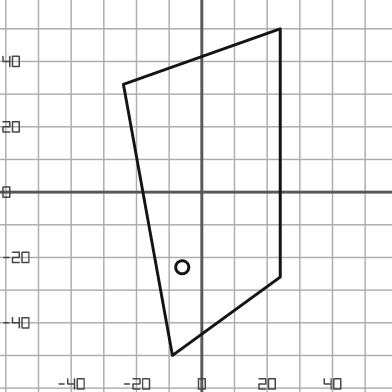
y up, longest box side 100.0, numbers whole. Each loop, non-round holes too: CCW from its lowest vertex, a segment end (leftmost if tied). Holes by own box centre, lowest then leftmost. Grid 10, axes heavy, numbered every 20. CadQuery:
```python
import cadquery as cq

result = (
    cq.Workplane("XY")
    .moveTo(-9.0, -50.0)
    .lineTo(24.0, -26.0)
    .lineTo(24.0, 50.0)
    .lineTo(-24.0, 33.0)
    .close()
    .moveTo(-6.0, -23.0)
    .circle(2.0)
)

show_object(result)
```